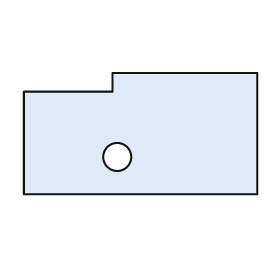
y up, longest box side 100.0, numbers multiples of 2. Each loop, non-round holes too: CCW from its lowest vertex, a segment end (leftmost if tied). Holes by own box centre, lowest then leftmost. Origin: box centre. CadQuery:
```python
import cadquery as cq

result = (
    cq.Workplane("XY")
    .moveTo(-50.0, -26.0)
    .lineTo(50.0, -26.0)
    .lineTo(50.0, 26.0)
    .lineTo(-12.0, 26.0)
    .lineTo(-12.0, 18.0)
    .lineTo(-50.0, 18.0)
    .close()
    .moveTo(-10.0, -10.0)
    .circle(6.0)
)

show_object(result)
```